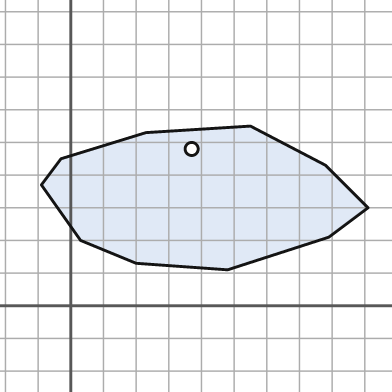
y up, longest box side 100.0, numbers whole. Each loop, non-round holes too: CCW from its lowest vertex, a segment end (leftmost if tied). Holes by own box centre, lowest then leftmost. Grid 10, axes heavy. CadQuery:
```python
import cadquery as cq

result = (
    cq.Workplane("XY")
    .moveTo(48.0, 11.0)
    .lineTo(79.0, 21.0)
    .lineTo(91.0, 30.0)
    .lineTo(78.0, 43.0)
    .lineTo(55.0, 55.0)
    .lineTo(23.0, 53.0)
    .lineTo(-3.0, 45.0)
    .lineTo(-9.0, 37.0)
    .lineTo(3.0, 20.0)
    .lineTo(20.0, 13.0)
    .close()
    .moveTo(37.0, 48.0)
    .circle(2.0)
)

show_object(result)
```